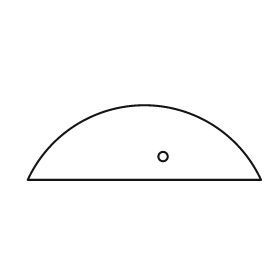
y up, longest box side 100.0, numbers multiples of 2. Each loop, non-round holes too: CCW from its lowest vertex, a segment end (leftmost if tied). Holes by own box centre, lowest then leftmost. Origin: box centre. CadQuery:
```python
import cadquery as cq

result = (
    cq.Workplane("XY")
    .moveTo(-50.0, -16.0)
    .lineTo(50.0, -16.0)
    .threePointArc((0.0, 16.0), (-50.0, -16.0))
    .close()
    .moveTo(8.0, -6.0)
    .circle(2.0)
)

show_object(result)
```